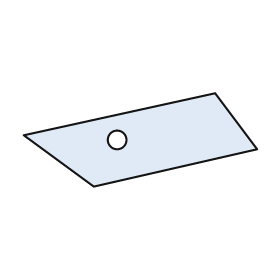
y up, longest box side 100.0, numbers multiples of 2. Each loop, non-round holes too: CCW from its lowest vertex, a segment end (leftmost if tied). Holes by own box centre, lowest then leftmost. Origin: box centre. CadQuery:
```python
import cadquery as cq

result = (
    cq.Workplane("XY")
    .moveTo(-20.0, -20.0)
    .lineTo(50.0, -4.0)
    .lineTo(32.0, 20.0)
    .lineTo(-50.0, 2.0)
    .close()
    .moveTo(-10.0, 0.0)
    .circle(4.0)
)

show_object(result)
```